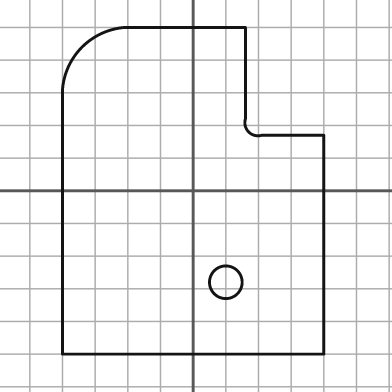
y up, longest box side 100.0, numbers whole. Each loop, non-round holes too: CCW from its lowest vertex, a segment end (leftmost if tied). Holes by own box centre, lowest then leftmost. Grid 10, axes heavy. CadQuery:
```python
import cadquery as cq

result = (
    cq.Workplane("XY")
    .moveTo(-40.0, -50.0)
    .lineTo(40.0, -50.0)
    .lineTo(40.0, 17.0)
    .lineTo(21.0, 17.0)
    .threePointArc((17.0, 18.0), (16.0, 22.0))
    .lineTo(16.0, 50.0)
    .lineTo(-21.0, 50.0)
    .threePointArc((-34.0, 44.0), (-40.0, 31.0))
    .close()
    .moveTo(10.0, -28.0)
    .circle(5.0)
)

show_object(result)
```